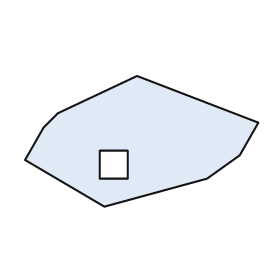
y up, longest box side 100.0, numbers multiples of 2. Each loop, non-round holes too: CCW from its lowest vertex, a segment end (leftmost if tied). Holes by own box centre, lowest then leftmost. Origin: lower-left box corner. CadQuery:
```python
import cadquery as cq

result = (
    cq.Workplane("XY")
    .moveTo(34.0, 0.0)
    .lineTo(78.0, 12.0)
    .lineTo(92.0, 22.0)
    .lineTo(100.0, 36.0)
    .lineTo(48.0, 56.0)
    .lineTo(14.0, 40.0)
    .lineTo(8.0, 34.0)
    .lineTo(0.0, 20.0)
    .close()
    .moveTo(32.0, 12.0)
    .lineTo(44.0, 12.0)
    .lineTo(44.0, 24.0)
    .lineTo(32.0, 24.0)
    .close()
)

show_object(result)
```